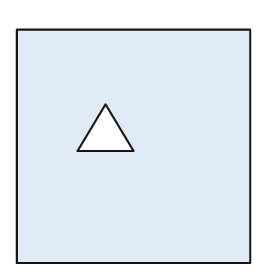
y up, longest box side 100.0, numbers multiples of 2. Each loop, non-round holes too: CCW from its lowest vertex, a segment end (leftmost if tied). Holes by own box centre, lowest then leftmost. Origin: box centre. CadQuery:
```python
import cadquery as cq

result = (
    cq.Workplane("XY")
    .moveTo(-50.0, -50.0)
    .lineTo(50.0, -50.0)
    .lineTo(50.0, 50.0)
    .lineTo(-50.0, 50.0)
    .close()
    .moveTo(-24.0, -2.0)
    .lineTo(0.0, -2.0)
    .lineTo(-12.0, 18.0)
    .close()
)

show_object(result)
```